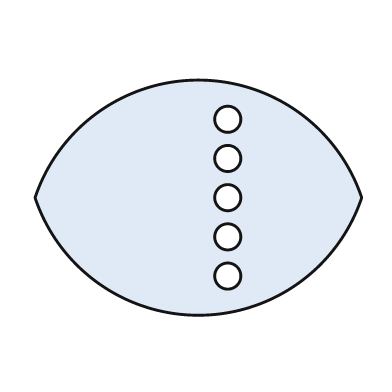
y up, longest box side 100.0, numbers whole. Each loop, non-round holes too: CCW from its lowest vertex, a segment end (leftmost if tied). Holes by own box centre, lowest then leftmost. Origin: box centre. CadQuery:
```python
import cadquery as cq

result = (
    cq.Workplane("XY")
    .moveTo(-50.0, 0.0)
    .threePointArc((0.0, -36.0), (50.0, 0.0))
    .threePointArc((0.0, 36.0), (-50.0, 0.0))
    .close()
    .moveTo(9.0, -24.0)
    .circle(4.0)
    .moveTo(9.0, -12.0)
    .circle(4.0)
    .moveTo(9.0, 0.0)
    .circle(4.0)
    .moveTo(9.0, 12.0)
    .circle(4.0)
    .moveTo(9.0, 24.0)
    .circle(4.0)
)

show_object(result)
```